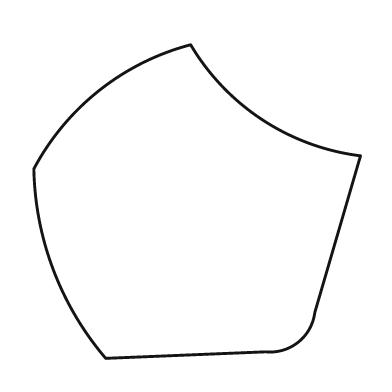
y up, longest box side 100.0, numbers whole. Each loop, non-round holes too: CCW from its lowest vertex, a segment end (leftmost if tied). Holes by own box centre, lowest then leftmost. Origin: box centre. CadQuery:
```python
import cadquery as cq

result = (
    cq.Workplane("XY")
    .moveTo(-28.0, -48.0)
    .lineTo(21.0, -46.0)
    .threePointArc((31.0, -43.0), (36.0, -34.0))
    .lineTo(50.0, 14.0)
    .threePointArc((20.0, 25.0), (-2.0, 48.0))
    .threePointArc((-30.0, 34.0), (-50.0, 10.0))
    .threePointArc((-44.0, -21.0), (-28.0, -48.0))
    .close()
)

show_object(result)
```